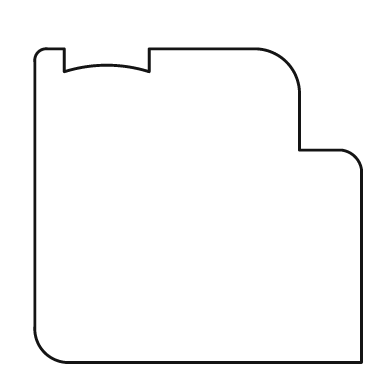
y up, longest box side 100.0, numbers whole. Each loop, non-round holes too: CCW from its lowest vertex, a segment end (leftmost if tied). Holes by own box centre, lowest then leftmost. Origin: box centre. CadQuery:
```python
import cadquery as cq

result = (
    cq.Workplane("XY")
    .moveTo(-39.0, -48.0)
    .lineTo(50.0, -48.0)
    .lineTo(50.0, 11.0)
    .threePointArc((48.0, 15.0), (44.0, 17.0))
    .lineTo(31.0, 17.0)
    .lineTo(31.0, 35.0)
    .threePointArc((27.0, 44.0), (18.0, 48.0))
    .lineTo(-15.0, 48.0)
    .lineTo(-15.0, 41.0)
    .threePointArc((-28.0, 43.0), (-41.0, 41.0))
    .lineTo(-41.0, 48.0)
    .lineTo(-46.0, 48.0)
    .threePointArc((-49.0, 47.0), (-50.0, 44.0))
    .lineTo(-50.0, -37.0)
    .threePointArc((-47.0, -45.0), (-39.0, -48.0))
    .close()
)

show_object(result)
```